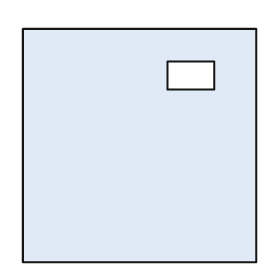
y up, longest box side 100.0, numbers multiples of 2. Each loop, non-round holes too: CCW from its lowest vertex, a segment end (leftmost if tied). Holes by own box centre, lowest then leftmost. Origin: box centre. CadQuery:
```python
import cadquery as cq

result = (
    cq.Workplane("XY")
    .moveTo(-50.0, -50.0)
    .lineTo(50.0, -50.0)
    .lineTo(50.0, 50.0)
    .lineTo(-50.0, 50.0)
    .close()
    .moveTo(12.0, 24.0)
    .lineTo(32.0, 24.0)
    .lineTo(32.0, 36.0)
    .lineTo(12.0, 36.0)
    .close()
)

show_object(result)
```